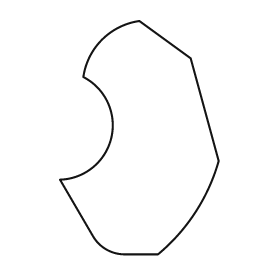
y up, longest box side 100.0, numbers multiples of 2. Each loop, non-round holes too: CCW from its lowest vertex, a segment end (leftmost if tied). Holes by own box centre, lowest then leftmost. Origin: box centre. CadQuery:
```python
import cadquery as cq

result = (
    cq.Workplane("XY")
    .moveTo(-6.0, -50.0)
    .lineTo(8.0, -50.0)
    .threePointArc((24.0, -32.0), (34.0, -10.0))
    .lineTo(22.0, 34.0)
    .lineTo(0.0, 50.0)
    .threePointArc((-16.0, 42.0), (-24.0, 26.0))
    .threePointArc((-12.0, 0.0), (-34.0, -18.0))
    .lineTo(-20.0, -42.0)
    .threePointArc((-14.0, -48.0), (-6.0, -50.0))
    .close()
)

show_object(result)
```